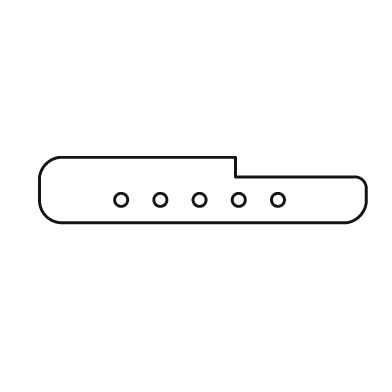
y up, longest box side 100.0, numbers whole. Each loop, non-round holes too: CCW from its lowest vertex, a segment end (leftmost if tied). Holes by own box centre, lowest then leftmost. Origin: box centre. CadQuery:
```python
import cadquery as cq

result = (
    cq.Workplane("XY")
    .moveTo(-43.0, -10.0)
    .lineTo(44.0, -10.0)
    .threePointArc((48.0, -8.0), (50.0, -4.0))
    .lineTo(50.0, 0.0)
    .threePointArc((49.0, 3.0), (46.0, 4.0))
    .lineTo(10.0, 4.0)
    .lineTo(10.0, 10.0)
    .lineTo(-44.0, 10.0)
    .threePointArc((-48.0, 8.0), (-50.0, 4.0))
    .lineTo(-50.0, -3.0)
    .threePointArc((-48.0, -8.0), (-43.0, -10.0))
    .close()
    .moveTo(-25.0, -3.0)
    .circle(2.0)
    .moveTo(-13.0, -3.0)
    .circle(2.0)
    .moveTo(-1.0, -3.0)
    .circle(2.0)
    .moveTo(11.0, -3.0)
    .circle(2.0)
    .moveTo(23.0, -3.0)
    .circle(2.0)
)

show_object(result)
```